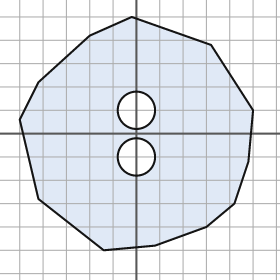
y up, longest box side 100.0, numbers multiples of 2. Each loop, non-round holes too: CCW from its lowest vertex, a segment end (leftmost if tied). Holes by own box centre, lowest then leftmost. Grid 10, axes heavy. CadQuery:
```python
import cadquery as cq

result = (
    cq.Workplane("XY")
    .moveTo(-14.0, -50.0)
    .lineTo(8.0, -48.0)
    .lineTo(30.0, -40.0)
    .lineTo(42.0, -30.0)
    .lineTo(48.0, -12.0)
    .lineTo(50.0, 10.0)
    .lineTo(32.0, 38.0)
    .lineTo(-2.0, 50.0)
    .lineTo(-20.0, 42.0)
    .lineTo(-42.0, 22.0)
    .lineTo(-50.0, 6.0)
    .lineTo(-42.0, -28.0)
    .close()
    .moveTo(0.0, -10.0)
    .circle(8.0)
    .moveTo(0.0, 10.0)
    .circle(8.0)
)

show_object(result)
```